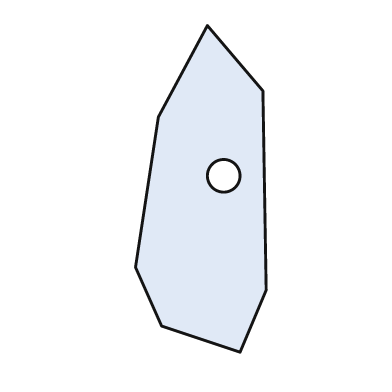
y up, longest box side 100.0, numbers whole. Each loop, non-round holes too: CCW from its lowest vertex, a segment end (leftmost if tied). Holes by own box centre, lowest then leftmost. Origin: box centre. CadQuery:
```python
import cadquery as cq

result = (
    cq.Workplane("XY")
    .moveTo(12.0, -50.0)
    .lineTo(20.0, -31.0)
    .lineTo(19.0, 30.0)
    .lineTo(2.0, 50.0)
    .lineTo(-13.0, 22.0)
    .lineTo(-20.0, -24.0)
    .lineTo(-12.0, -42.0)
    .close()
    .moveTo(7.0, 4.0)
    .circle(5.0)
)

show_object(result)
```